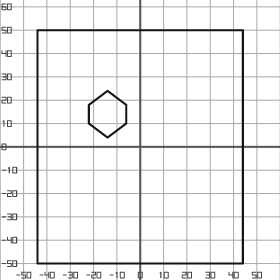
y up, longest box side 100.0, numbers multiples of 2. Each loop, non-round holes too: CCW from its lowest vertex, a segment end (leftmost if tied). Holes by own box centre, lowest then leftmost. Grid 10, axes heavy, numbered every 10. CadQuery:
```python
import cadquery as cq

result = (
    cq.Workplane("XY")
    .moveTo(-44.0, -50.0)
    .lineTo(44.0, -50.0)
    .lineTo(44.0, 50.0)
    .lineTo(-44.0, 50.0)
    .close()
    .moveTo(-14.0, 4.0)
    .lineTo(-6.0, 10.0)
    .lineTo(-6.0, 18.0)
    .lineTo(-14.0, 24.0)
    .lineTo(-22.0, 18.0)
    .lineTo(-22.0, 10.0)
    .close()
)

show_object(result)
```